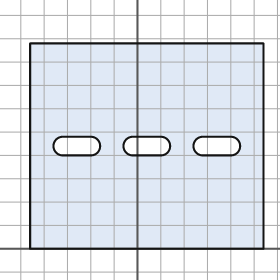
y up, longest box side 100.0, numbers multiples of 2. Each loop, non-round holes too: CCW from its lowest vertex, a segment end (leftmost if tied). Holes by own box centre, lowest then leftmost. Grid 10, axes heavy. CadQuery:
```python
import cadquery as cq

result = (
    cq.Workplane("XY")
    .moveTo(-46.0, 0.0)
    .lineTo(54.0, 0.0)
    .lineTo(54.0, 88.0)
    .lineTo(-46.0, 88.0)
    .close()
    .moveTo(-32.0, 40.0)
    .lineTo(-20.0, 40.0)
    .threePointArc((-16.0, 44.0), (-20.0, 48.0))
    .lineTo(-32.0, 48.0)
    .threePointArc((-36.0, 44.0), (-32.0, 40.0))
    .close()
    .moveTo(-2.0, 40.0)
    .lineTo(10.0, 40.0)
    .threePointArc((14.0, 44.0), (10.0, 48.0))
    .lineTo(-2.0, 48.0)
    .threePointArc((-6.0, 44.0), (-2.0, 40.0))
    .close()
    .moveTo(28.0, 40.0)
    .lineTo(40.0, 40.0)
    .threePointArc((44.0, 44.0), (40.0, 48.0))
    .lineTo(28.0, 48.0)
    .threePointArc((24.0, 44.0), (28.0, 40.0))
    .close()
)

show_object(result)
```